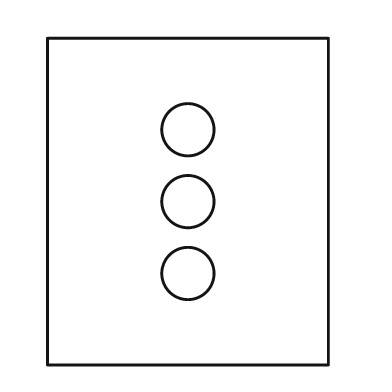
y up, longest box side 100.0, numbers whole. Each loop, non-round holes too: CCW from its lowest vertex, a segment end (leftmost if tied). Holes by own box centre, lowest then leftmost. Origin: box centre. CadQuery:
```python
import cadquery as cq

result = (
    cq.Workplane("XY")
    .moveTo(-43.0, -50.0)
    .lineTo(43.0, -50.0)
    .lineTo(43.0, 50.0)
    .lineTo(-43.0, 50.0)
    .close()
    .moveTo(0.0, -22.0)
    .circle(8.0)
    .moveTo(0.0, 0.0)
    .circle(8.0)
    .moveTo(0.0, 22.0)
    .circle(8.0)
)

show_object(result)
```